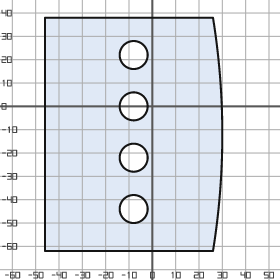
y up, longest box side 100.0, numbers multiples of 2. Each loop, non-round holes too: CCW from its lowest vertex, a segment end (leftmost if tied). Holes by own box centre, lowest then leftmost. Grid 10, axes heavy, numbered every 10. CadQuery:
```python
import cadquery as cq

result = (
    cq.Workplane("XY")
    .moveTo(-46.0, -62.0)
    .lineTo(26.0, -62.0)
    .threePointArc((30.0, -12.0), (26.0, 38.0))
    .lineTo(-46.0, 38.0)
    .close()
    .moveTo(-8.0, -44.0)
    .circle(6.0)
    .moveTo(-8.0, -22.0)
    .circle(6.0)
    .moveTo(-8.0, 0.0)
    .circle(6.0)
    .moveTo(-8.0, 22.0)
    .circle(6.0)
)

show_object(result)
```